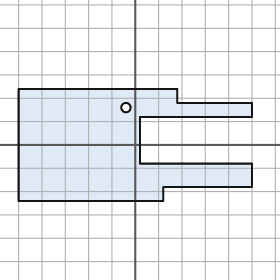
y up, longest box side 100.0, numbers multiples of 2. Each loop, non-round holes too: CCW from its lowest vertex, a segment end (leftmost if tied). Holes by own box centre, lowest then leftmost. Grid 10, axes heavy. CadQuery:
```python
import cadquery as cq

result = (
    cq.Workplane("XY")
    .moveTo(-50.0, -24.0)
    .lineTo(12.0, -24.0)
    .lineTo(12.0, -18.0)
    .lineTo(50.0, -18.0)
    .lineTo(50.0, -8.0)
    .lineTo(2.0, -8.0)
    .lineTo(2.0, 12.0)
    .lineTo(50.0, 12.0)
    .lineTo(50.0, 18.0)
    .lineTo(18.0, 18.0)
    .lineTo(18.0, 24.0)
    .lineTo(-50.0, 24.0)
    .close()
    .moveTo(-4.0, 16.0)
    .circle(2.0)
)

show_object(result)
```